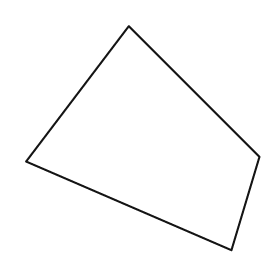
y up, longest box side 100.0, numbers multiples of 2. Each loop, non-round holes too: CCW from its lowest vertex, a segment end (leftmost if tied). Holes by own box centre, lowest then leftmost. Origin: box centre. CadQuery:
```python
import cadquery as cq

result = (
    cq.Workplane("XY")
    .moveTo(38.0, -48.0)
    .lineTo(50.0, -8.0)
    .lineTo(-6.0, 48.0)
    .lineTo(-50.0, -10.0)
    .close()
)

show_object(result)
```